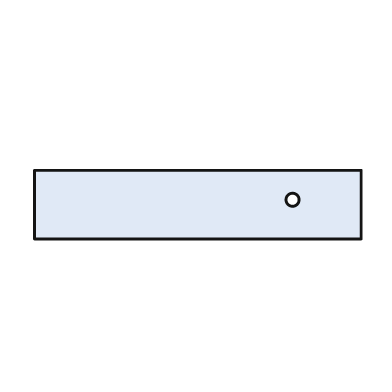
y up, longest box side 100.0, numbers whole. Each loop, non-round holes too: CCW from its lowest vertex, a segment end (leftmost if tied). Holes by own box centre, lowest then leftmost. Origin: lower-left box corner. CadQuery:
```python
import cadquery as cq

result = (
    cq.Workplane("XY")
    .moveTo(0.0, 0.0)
    .lineTo(100.0, 0.0)
    .lineTo(100.0, 21.0)
    .lineTo(0.0, 21.0)
    .close()
    .moveTo(79.0, 12.0)
    .circle(2.0)
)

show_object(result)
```